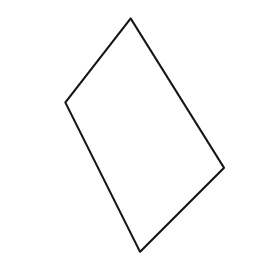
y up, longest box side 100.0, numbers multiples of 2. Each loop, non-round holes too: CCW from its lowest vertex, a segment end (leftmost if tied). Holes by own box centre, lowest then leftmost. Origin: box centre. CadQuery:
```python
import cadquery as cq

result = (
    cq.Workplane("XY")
    .moveTo(-2.0, -50.0)
    .lineTo(34.0, -14.0)
    .lineTo(-6.0, 50.0)
    .lineTo(-34.0, 14.0)
    .close()
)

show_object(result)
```